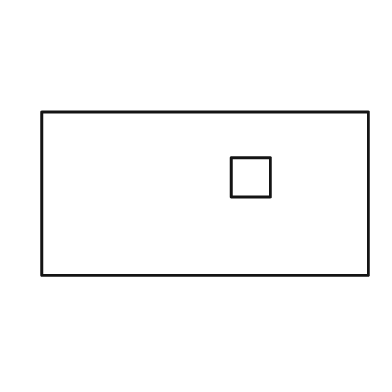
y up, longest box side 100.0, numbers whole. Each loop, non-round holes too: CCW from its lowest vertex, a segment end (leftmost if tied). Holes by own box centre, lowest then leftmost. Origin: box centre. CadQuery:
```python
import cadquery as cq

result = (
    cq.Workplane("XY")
    .moveTo(-50.0, -25.0)
    .lineTo(50.0, -25.0)
    .lineTo(50.0, 25.0)
    .lineTo(-50.0, 25.0)
    .close()
    .moveTo(8.0, -1.0)
    .lineTo(20.0, -1.0)
    .lineTo(20.0, 11.0)
    .lineTo(8.0, 11.0)
    .close()
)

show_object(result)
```